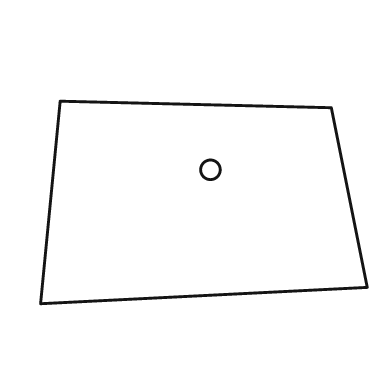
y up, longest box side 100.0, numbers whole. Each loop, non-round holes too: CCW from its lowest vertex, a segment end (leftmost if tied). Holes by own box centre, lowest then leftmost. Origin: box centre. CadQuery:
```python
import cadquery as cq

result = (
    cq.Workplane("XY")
    .moveTo(-50.0, -31.0)
    .lineTo(50.0, -26.0)
    .lineTo(39.0, 29.0)
    .lineTo(-44.0, 31.0)
    .close()
    .moveTo(2.0, 10.0)
    .circle(3.0)
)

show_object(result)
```